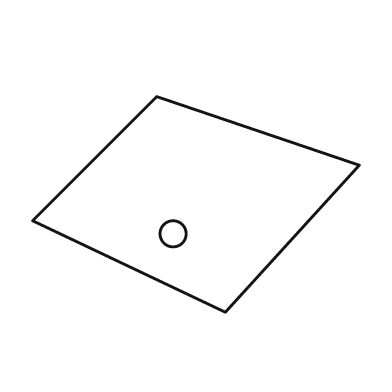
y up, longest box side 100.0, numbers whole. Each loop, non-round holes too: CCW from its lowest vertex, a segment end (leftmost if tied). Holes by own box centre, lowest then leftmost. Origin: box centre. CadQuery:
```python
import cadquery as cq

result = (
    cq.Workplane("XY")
    .moveTo(9.0, -33.0)
    .lineTo(50.0, 12.0)
    .lineTo(-12.0, 33.0)
    .lineTo(-50.0, -5.0)
    .close()
    .moveTo(-7.0, -9.0)
    .circle(4.0)
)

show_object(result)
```